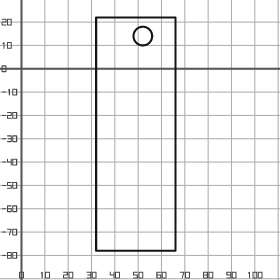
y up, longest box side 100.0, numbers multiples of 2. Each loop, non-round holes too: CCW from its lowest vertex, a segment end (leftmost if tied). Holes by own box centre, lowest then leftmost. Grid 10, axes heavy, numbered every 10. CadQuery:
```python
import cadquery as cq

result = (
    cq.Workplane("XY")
    .moveTo(32.0, -78.0)
    .lineTo(66.0, -78.0)
    .lineTo(66.0, 22.0)
    .lineTo(32.0, 22.0)
    .close()
    .moveTo(52.0, 14.0)
    .circle(4.0)
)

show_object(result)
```